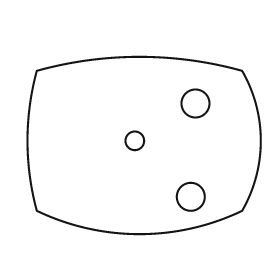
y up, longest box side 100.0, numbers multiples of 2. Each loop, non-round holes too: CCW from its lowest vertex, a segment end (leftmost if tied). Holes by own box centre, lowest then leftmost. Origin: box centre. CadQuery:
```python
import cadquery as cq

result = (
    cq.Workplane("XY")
    .moveTo(-46.0, -28.0)
    .threePointArc((-2.0, -38.0), (42.0, -28.0))
    .threePointArc((50.0, 2.0), (42.0, 32.0))
    .threePointArc((-2.0, 38.0), (-46.0, 32.0))
    .threePointArc((-50.0, 2.0), (-46.0, -28.0))
    .close()
    .moveTo(20.0, -22.0)
    .circle(6.0)
    .moveTo(-4.0, 2.0)
    .circle(4.0)
    .moveTo(22.0, 18.0)
    .circle(6.0)
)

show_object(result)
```